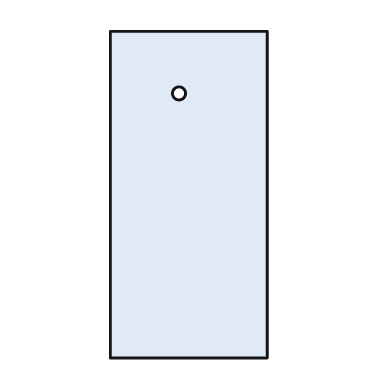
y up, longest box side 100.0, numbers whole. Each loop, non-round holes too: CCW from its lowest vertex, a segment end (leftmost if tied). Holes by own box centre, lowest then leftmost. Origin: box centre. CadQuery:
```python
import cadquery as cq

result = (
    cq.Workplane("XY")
    .moveTo(-24.0, -50.0)
    .lineTo(24.0, -50.0)
    .lineTo(24.0, 50.0)
    .lineTo(-24.0, 50.0)
    .close()
    .moveTo(-3.0, 31.0)
    .circle(2.0)
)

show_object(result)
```